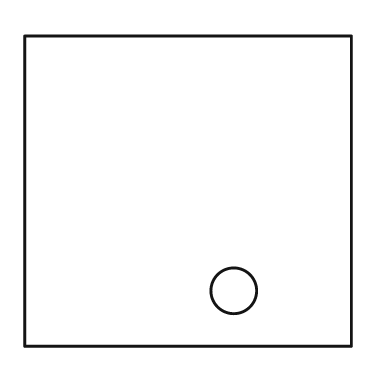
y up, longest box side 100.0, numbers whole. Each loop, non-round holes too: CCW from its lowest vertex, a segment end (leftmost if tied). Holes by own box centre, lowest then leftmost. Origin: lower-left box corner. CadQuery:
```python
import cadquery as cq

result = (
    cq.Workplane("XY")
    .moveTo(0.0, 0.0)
    .lineTo(100.0, 0.0)
    .lineTo(100.0, 95.0)
    .lineTo(0.0, 95.0)
    .close()
    .moveTo(64.0, 17.0)
    .circle(7.0)
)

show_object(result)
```